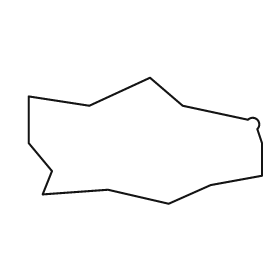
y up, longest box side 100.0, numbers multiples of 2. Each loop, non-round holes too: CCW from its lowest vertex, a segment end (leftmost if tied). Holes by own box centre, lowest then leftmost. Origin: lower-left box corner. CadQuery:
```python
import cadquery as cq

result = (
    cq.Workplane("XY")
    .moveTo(60.0, 0.0)
    .lineTo(78.0, 8.0)
    .lineTo(100.0, 12.0)
    .lineTo(100.0, 26.0)
    .lineTo(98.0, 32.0)
    .threePointArc((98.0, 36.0), (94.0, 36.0))
    .lineTo(66.0, 42.0)
    .lineTo(52.0, 54.0)
    .lineTo(26.0, 42.0)
    .lineTo(0.0, 46.0)
    .lineTo(0.0, 26.0)
    .lineTo(10.0, 14.0)
    .lineTo(6.0, 4.0)
    .lineTo(34.0, 6.0)
    .close()
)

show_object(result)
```